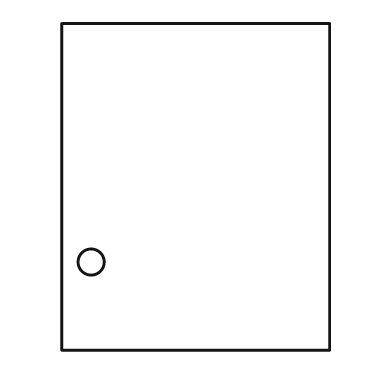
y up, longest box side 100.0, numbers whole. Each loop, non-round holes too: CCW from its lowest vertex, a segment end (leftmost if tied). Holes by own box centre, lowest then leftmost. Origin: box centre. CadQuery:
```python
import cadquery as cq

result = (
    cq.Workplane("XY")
    .moveTo(-41.0, -50.0)
    .lineTo(41.0, -50.0)
    .lineTo(41.0, 50.0)
    .lineTo(-41.0, 50.0)
    .close()
    .moveTo(-32.0, -23.0)
    .circle(4.0)
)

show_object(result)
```